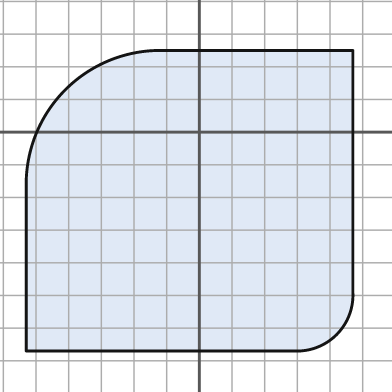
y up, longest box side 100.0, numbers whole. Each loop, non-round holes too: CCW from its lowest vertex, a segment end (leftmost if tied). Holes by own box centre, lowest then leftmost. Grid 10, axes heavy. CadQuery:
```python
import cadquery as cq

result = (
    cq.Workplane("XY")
    .moveTo(-53.0, -67.0)
    .lineTo(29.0, -67.0)
    .threePointArc((42.0, -62.0), (47.0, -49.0))
    .lineTo(47.0, 25.0)
    .lineTo(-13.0, 25.0)
    .threePointArc((-41.0, 13.0), (-53.0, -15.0))
    .close()
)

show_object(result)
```